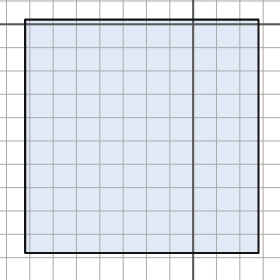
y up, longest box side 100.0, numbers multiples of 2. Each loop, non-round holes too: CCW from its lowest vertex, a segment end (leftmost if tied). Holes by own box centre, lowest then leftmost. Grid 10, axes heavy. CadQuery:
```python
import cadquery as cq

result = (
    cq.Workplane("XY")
    .moveTo(-72.0, -98.0)
    .lineTo(28.0, -98.0)
    .lineTo(28.0, 2.0)
    .lineTo(-72.0, 2.0)
    .close()
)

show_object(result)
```